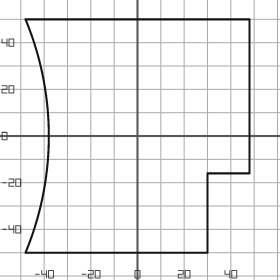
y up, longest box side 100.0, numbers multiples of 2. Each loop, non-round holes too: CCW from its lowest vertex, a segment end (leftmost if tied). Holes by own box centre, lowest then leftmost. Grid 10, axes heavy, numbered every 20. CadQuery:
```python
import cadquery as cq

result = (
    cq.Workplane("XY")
    .moveTo(-48.0, -50.0)
    .lineTo(30.0, -50.0)
    .lineTo(30.0, -16.0)
    .lineTo(48.0, -16.0)
    .lineTo(48.0, 50.0)
    .lineTo(-48.0, 50.0)
    .threePointArc((-38.0, 0.0), (-48.0, -50.0))
    .close()
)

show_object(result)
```